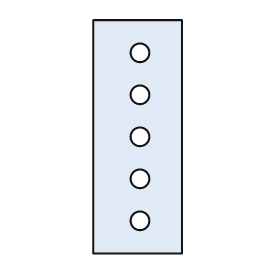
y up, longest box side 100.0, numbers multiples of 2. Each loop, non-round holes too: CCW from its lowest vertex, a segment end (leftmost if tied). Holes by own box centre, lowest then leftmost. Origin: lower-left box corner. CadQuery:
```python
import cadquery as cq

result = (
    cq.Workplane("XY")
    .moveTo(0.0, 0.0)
    .lineTo(38.0, 0.0)
    .lineTo(38.0, 100.0)
    .lineTo(0.0, 100.0)
    .close()
    .moveTo(20.0, 14.0)
    .circle(4.0)
    .moveTo(20.0, 32.0)
    .circle(4.0)
    .moveTo(20.0, 50.0)
    .circle(4.0)
    .moveTo(20.0, 68.0)
    .circle(4.0)
    .moveTo(20.0, 86.0)
    .circle(4.0)
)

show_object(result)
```